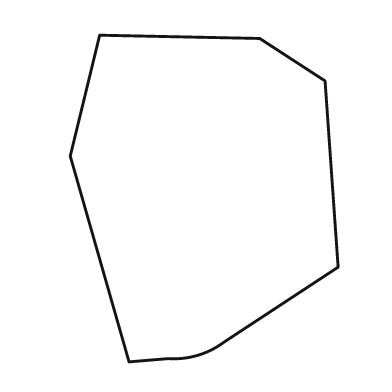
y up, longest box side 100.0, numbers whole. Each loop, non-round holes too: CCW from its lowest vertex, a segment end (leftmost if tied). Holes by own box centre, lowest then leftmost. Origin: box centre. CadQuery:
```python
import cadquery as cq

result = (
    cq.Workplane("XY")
    .moveTo(-23.0, -50.0)
    .lineTo(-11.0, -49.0)
    .threePointArc((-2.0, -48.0), (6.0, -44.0))
    .lineTo(41.0, -21.0)
    .lineTo(37.0, 36.0)
    .lineTo(17.0, 49.0)
    .lineTo(-32.0, 50.0)
    .lineTo(-41.0, 13.0)
    .close()
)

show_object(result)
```